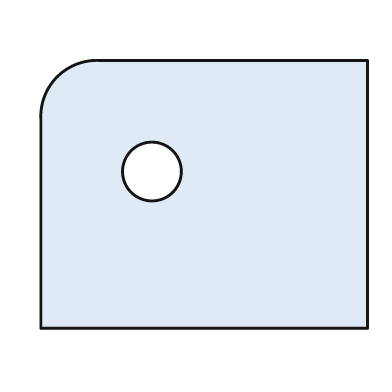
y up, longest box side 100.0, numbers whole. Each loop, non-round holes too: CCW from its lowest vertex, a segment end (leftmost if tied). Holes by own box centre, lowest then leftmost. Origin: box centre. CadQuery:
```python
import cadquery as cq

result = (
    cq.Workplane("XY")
    .moveTo(-50.0, -41.0)
    .lineTo(50.0, -41.0)
    .lineTo(50.0, 41.0)
    .lineTo(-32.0, 41.0)
    .threePointArc((-45.0, 36.0), (-50.0, 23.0))
    .close()
    .moveTo(-16.0, 7.0)
    .circle(9.0)
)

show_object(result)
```